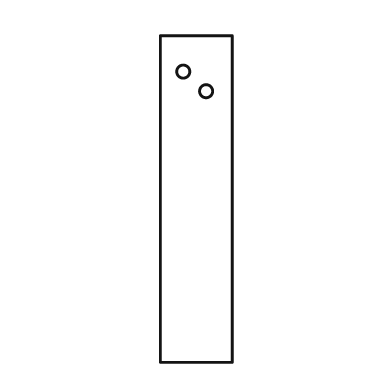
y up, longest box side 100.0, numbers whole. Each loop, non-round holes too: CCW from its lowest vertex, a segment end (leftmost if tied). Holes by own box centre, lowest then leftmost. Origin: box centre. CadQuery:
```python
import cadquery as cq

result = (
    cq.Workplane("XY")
    .moveTo(-11.0, -50.0)
    .lineTo(11.0, -50.0)
    .lineTo(11.0, 50.0)
    .lineTo(-11.0, 50.0)
    .close()
    .moveTo(3.0, 33.0)
    .circle(2.0)
    .moveTo(-4.0, 39.0)
    .circle(2.0)
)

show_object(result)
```